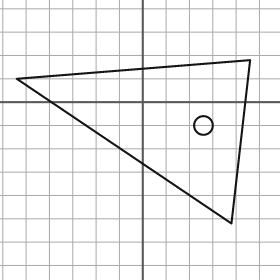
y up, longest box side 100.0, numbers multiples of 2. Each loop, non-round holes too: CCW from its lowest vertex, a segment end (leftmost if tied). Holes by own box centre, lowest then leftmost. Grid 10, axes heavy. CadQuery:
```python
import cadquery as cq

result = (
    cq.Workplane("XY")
    .moveTo(38.0, -52.0)
    .lineTo(46.0, 18.0)
    .lineTo(-54.0, 10.0)
    .close()
    .moveTo(26.0, -10.0)
    .circle(4.0)
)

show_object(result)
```